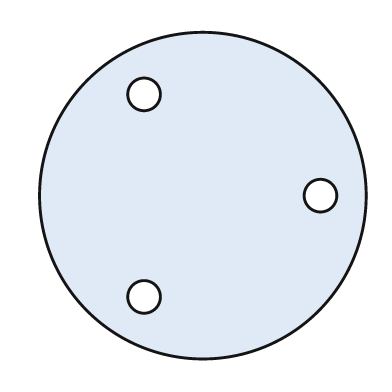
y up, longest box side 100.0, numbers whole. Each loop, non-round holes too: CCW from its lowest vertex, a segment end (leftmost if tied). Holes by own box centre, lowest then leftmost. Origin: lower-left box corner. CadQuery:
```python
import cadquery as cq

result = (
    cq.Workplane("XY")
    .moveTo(50.0, 50.0)
    .circle(50.0)
    .moveTo(32.0, 19.0)
    .circle(5.0)
    .moveTo(86.0, 50.0)
    .circle(5.0)
    .moveTo(32.0, 81.0)
    .circle(5.0)
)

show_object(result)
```